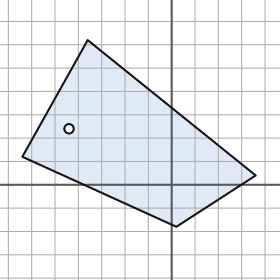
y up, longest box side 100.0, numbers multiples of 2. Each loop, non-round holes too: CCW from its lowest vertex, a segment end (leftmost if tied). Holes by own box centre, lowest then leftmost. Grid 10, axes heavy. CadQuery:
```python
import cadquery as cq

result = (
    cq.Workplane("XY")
    .moveTo(2.0, -18.0)
    .lineTo(36.0, 4.0)
    .lineTo(-36.0, 62.0)
    .lineTo(-64.0, 12.0)
    .close()
    .moveTo(-44.0, 24.0)
    .circle(2.0)
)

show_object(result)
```